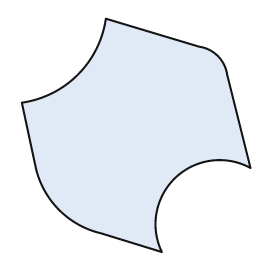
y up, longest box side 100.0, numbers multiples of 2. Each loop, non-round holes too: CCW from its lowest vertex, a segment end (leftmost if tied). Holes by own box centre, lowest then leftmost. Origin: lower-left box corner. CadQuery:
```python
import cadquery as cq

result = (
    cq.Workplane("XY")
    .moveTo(60.0, 0.0)
    .threePointArc((66.0, 32.0), (98.0, 36.0))
    .lineTo(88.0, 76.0)
    .threePointArc((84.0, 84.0), (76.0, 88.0))
    .lineTo(36.0, 100.0)
    .threePointArc((24.0, 76.0), (0.0, 64.0))
    .lineTo(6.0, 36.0)
    .threePointArc((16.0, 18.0), (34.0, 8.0))
    .close()
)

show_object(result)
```